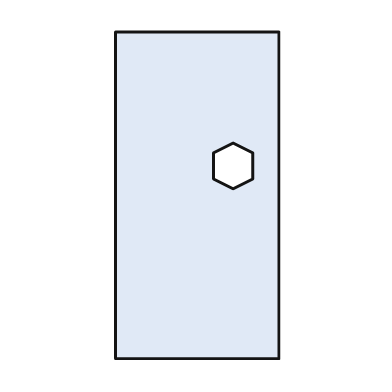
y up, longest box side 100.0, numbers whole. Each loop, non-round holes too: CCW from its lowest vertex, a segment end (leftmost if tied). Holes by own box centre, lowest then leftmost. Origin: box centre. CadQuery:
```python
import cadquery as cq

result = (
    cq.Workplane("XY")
    .moveTo(-25.0, -50.0)
    .lineTo(25.0, -50.0)
    .lineTo(25.0, 50.0)
    .lineTo(-25.0, 50.0)
    .close()
    .moveTo(11.0, 2.0)
    .lineTo(17.0, 5.0)
    .lineTo(17.0, 13.0)
    .lineTo(11.0, 16.0)
    .lineTo(5.0, 13.0)
    .lineTo(5.0, 5.0)
    .close()
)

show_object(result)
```